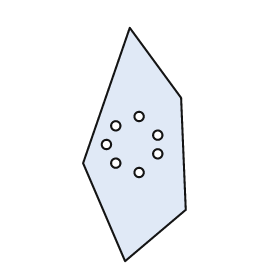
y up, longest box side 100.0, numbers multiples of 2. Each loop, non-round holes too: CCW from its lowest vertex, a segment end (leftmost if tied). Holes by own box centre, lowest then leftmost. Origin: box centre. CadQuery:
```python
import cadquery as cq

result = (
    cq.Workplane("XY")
    .moveTo(-4.0, -50.0)
    .lineTo(22.0, -28.0)
    .lineTo(20.0, 20.0)
    .lineTo(-2.0, 50.0)
    .lineTo(-22.0, -8.0)
    .close()
    .moveTo(2.0, -12.0)
    .circle(2.0)
    .moveTo(-8.0, -8.0)
    .circle(2.0)
    .moveTo(10.0, -4.0)
    .circle(2.0)
    .moveTo(-12.0, 0.0)
    .circle(2.0)
    .moveTo(10.0, 4.0)
    .circle(2.0)
    .moveTo(-8.0, 8.0)
    .circle(2.0)
    .moveTo(2.0, 12.0)
    .circle(2.0)
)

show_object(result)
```